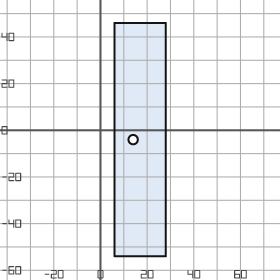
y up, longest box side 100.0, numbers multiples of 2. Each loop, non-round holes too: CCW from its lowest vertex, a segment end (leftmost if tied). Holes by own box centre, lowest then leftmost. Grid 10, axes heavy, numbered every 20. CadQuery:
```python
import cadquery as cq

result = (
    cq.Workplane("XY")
    .moveTo(6.0, -54.0)
    .lineTo(28.0, -54.0)
    .lineTo(28.0, 46.0)
    .lineTo(6.0, 46.0)
    .close()
    .moveTo(14.0, -4.0)
    .circle(2.0)
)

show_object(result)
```